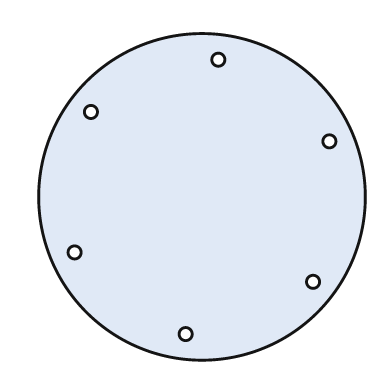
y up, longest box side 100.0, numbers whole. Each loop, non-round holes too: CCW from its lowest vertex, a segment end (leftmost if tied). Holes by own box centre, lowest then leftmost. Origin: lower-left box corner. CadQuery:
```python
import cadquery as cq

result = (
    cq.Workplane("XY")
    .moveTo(50.0, 50.0)
    .circle(50.0)
    .moveTo(45.0, 8.0)
    .circle(2.0)
    .moveTo(84.0, 24.0)
    .circle(2.0)
    .moveTo(11.0, 33.0)
    .circle(2.0)
    .moveTo(89.0, 67.0)
    .circle(2.0)
    .moveTo(16.0, 76.0)
    .circle(2.0)
    .moveTo(55.0, 92.0)
    .circle(2.0)
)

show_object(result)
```